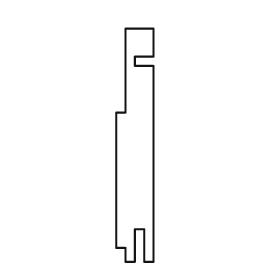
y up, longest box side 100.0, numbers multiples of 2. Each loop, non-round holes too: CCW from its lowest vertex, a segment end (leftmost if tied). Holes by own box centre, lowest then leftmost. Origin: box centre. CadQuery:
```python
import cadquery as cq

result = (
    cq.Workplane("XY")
    .moveTo(-4.0, -50.0)
    .lineTo(0.0, -50.0)
    .lineTo(0.0, -36.0)
    .lineTo(4.0, -36.0)
    .lineTo(4.0, -50.0)
    .lineTo(8.0, -50.0)
    .lineTo(8.0, 34.0)
    .lineTo(0.0, 34.0)
    .lineTo(0.0, 38.0)
    .lineTo(8.0, 38.0)
    .lineTo(8.0, 50.0)
    .lineTo(-4.0, 50.0)
    .lineTo(-4.0, 14.0)
    .lineTo(-8.0, 14.0)
    .lineTo(-8.0, -44.0)
    .lineTo(-4.0, -44.0)
    .close()
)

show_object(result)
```